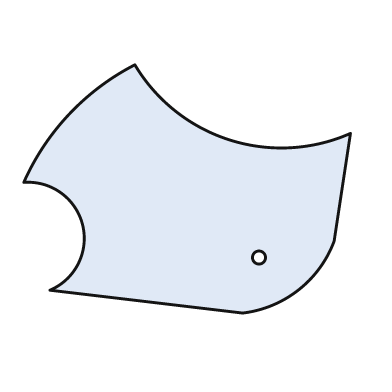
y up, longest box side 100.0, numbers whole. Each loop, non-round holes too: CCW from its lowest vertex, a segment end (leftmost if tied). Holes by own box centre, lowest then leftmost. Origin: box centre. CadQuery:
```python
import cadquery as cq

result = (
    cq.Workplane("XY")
    .moveTo(17.0, -38.0)
    .threePointArc((34.0, -31.0), (45.0, -16.0))
    .lineTo(50.0, 17.0)
    .threePointArc((13.0, 15.0), (-16.0, 38.0))
    .threePointArc((-36.0, 23.0), (-50.0, 2.0))
    .threePointArc((-32.0, -11.0), (-42.0, -31.0))
    .close()
    .moveTo(22.0, -21.0)
    .circle(2.0)
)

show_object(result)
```